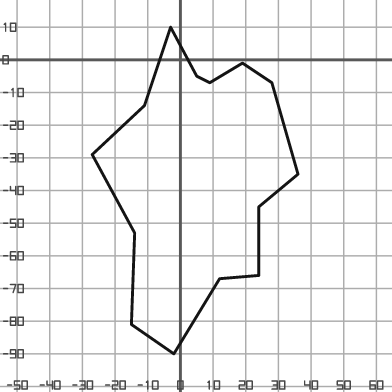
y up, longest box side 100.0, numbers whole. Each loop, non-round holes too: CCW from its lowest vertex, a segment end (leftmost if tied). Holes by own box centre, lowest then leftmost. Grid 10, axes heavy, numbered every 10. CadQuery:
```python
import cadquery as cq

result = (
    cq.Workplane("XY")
    .moveTo(-2.0, -90.0)
    .lineTo(12.0, -67.0)
    .lineTo(24.0, -66.0)
    .lineTo(24.0, -45.0)
    .lineTo(36.0, -35.0)
    .lineTo(28.0, -7.0)
    .lineTo(19.0, -1.0)
    .lineTo(9.0, -7.0)
    .lineTo(5.0, -5.0)
    .lineTo(-3.0, 10.0)
    .lineTo(-11.0, -14.0)
    .lineTo(-27.0, -29.0)
    .lineTo(-14.0, -53.0)
    .lineTo(-15.0, -81.0)
    .close()
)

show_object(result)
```